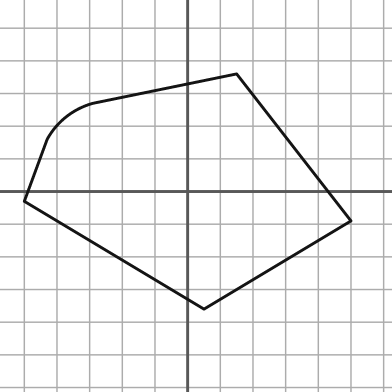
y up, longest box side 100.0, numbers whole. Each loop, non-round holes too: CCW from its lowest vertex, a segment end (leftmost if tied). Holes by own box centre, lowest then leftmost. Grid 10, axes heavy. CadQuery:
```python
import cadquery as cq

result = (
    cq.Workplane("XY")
    .moveTo(5.0, -36.0)
    .lineTo(50.0, -9.0)
    .lineTo(15.0, 36.0)
    .lineTo(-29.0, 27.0)
    .threePointArc((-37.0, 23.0), (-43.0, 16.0))
    .lineTo(-50.0, -3.0)
    .close()
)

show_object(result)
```